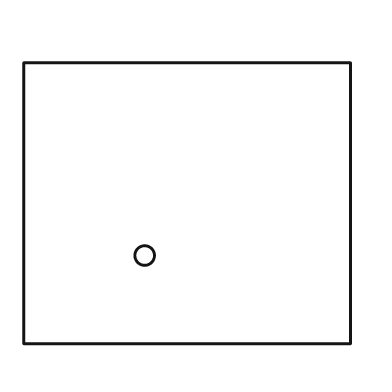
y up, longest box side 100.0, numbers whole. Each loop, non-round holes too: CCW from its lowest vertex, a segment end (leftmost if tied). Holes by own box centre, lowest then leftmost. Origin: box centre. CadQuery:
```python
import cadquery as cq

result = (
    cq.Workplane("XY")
    .moveTo(-50.0, -43.0)
    .lineTo(50.0, -43.0)
    .lineTo(50.0, 43.0)
    .lineTo(-50.0, 43.0)
    .close()
    .moveTo(-13.0, -16.0)
    .circle(3.0)
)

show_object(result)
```